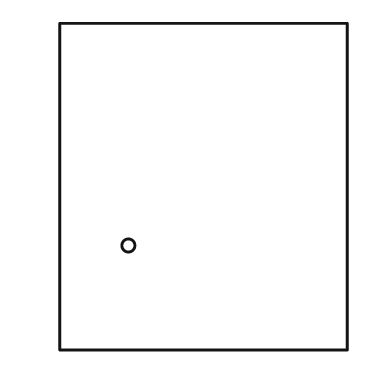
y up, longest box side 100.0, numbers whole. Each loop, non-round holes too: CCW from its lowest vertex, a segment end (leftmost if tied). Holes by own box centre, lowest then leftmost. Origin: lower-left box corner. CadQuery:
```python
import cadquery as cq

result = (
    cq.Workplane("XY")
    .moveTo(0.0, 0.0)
    .lineTo(88.0, 0.0)
    .lineTo(88.0, 100.0)
    .lineTo(0.0, 100.0)
    .close()
    .moveTo(21.0, 32.0)
    .circle(2.0)
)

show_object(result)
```